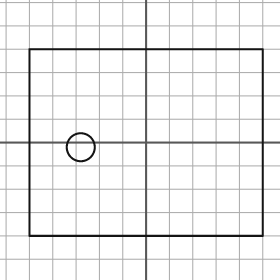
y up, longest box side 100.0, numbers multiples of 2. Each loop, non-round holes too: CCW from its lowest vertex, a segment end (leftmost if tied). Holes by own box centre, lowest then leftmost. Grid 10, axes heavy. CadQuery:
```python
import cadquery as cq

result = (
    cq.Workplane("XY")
    .moveTo(-50.0, -40.0)
    .lineTo(50.0, -40.0)
    .lineTo(50.0, 40.0)
    .lineTo(-50.0, 40.0)
    .close()
    .moveTo(-28.0, -2.0)
    .circle(6.0)
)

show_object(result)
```